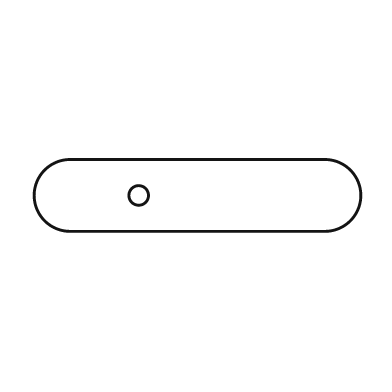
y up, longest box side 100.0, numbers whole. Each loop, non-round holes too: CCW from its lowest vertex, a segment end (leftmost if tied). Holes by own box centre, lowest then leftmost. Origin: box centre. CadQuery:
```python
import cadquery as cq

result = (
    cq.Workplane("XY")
    .moveTo(-39.0, -11.0)
    .lineTo(39.0, -11.0)
    .threePointArc((50.0, 0.0), (39.0, 11.0))
    .lineTo(-39.0, 11.0)
    .threePointArc((-50.0, 0.0), (-39.0, -11.0))
    .close()
    .moveTo(-18.0, 0.0)
    .circle(3.0)
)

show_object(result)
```